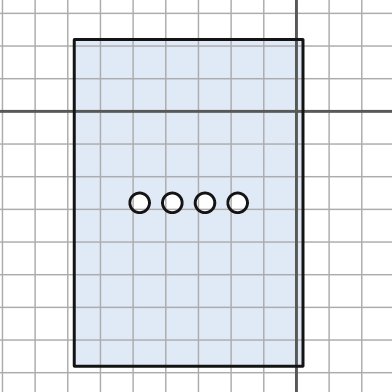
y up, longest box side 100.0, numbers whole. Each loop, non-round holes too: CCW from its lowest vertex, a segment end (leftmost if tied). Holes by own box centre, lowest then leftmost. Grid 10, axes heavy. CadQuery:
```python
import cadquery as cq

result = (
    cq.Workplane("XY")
    .moveTo(-68.0, -78.0)
    .lineTo(2.0, -78.0)
    .lineTo(2.0, 22.0)
    .lineTo(-68.0, 22.0)
    .close()
    .moveTo(-48.0, -28.0)
    .circle(3.0)
    .moveTo(-38.0, -28.0)
    .circle(3.0)
    .moveTo(-28.0, -28.0)
    .circle(3.0)
    .moveTo(-18.0, -28.0)
    .circle(3.0)
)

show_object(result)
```